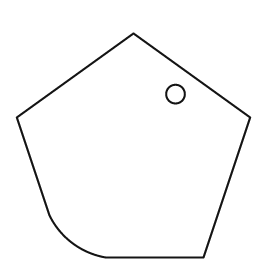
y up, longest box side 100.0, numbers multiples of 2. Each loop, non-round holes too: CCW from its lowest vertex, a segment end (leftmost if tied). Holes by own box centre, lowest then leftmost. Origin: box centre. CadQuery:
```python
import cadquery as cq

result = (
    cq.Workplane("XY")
    .moveTo(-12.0, -48.0)
    .lineTo(30.0, -48.0)
    .lineTo(50.0, 12.0)
    .lineTo(0.0, 48.0)
    .lineTo(-50.0, 12.0)
    .lineTo(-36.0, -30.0)
    .threePointArc((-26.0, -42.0), (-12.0, -48.0))
    .close()
    .moveTo(18.0, 22.0)
    .circle(4.0)
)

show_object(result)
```